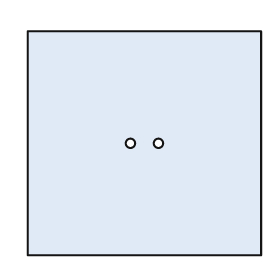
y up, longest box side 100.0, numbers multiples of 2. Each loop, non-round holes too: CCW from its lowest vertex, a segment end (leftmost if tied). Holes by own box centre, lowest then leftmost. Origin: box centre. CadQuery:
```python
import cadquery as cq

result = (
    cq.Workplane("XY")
    .moveTo(-50.0, -48.0)
    .lineTo(50.0, -48.0)
    .lineTo(50.0, 48.0)
    .lineTo(-50.0, 48.0)
    .close()
    .moveTo(-6.0, 0.0)
    .circle(2.0)
    .moveTo(6.0, 0.0)
    .circle(2.0)
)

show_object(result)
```